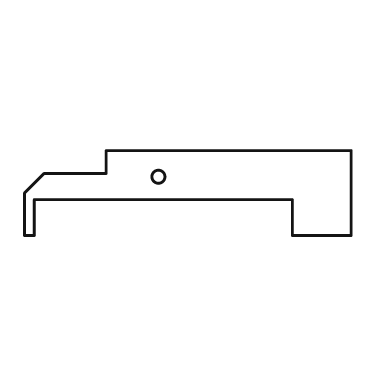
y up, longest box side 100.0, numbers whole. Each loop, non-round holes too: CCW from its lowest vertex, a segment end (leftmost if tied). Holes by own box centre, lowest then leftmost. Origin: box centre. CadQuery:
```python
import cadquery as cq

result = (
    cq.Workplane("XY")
    .moveTo(-50.0, -13.0)
    .lineTo(-47.0, -13.0)
    .lineTo(-47.0, -2.0)
    .lineTo(32.0, -2.0)
    .lineTo(32.0, -13.0)
    .lineTo(50.0, -13.0)
    .lineTo(50.0, 13.0)
    .lineTo(-25.0, 13.0)
    .lineTo(-25.0, 6.0)
    .lineTo(-44.0, 6.0)
    .lineTo(-50.0, 0.0)
    .close()
    .moveTo(-9.0, 5.0)
    .circle(2.0)
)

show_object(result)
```